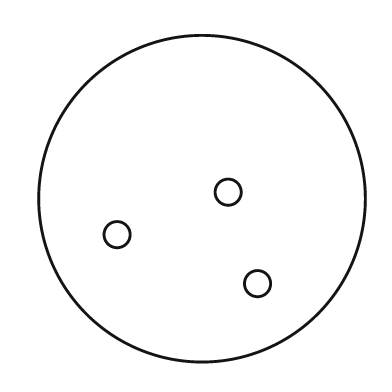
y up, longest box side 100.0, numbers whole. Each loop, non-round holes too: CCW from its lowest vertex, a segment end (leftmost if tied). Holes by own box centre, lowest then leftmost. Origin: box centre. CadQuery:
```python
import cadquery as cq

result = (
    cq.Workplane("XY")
    .moveTo(0.0, 0.0)
    .circle(50.0)
    .moveTo(17.0, -26.0)
    .circle(4.0)
    .moveTo(-26.0, -11.0)
    .circle(4.0)
    .moveTo(8.0, 2.0)
    .circle(4.0)
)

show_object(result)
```